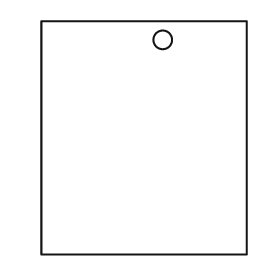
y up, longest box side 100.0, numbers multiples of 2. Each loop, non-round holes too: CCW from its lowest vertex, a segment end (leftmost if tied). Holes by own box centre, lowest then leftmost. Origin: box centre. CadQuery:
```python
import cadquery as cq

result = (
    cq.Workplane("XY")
    .moveTo(-44.0, -50.0)
    .lineTo(44.0, -50.0)
    .lineTo(44.0, 50.0)
    .lineTo(-44.0, 50.0)
    .close()
    .moveTo(8.0, 42.0)
    .circle(4.0)
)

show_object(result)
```